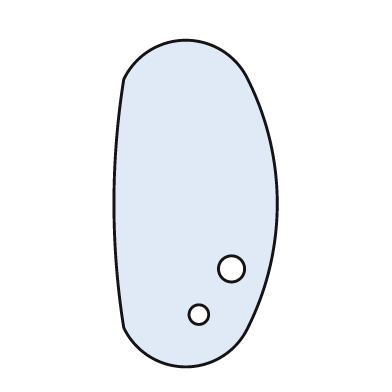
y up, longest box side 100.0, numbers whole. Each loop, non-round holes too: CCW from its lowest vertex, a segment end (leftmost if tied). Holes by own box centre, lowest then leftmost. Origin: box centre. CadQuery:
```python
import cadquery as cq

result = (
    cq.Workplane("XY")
    .moveTo(-22.0, -38.0)
    .threePointArc((-3.0, -50.0), (16.0, -38.0))
    .threePointArc((25.0, 0.0), (16.0, 38.0))
    .threePointArc((-3.0, 50.0), (-22.0, 38.0))
    .threePointArc((-25.0, 0.0), (-22.0, -38.0))
    .close()
    .moveTo(1.0, -34.0)
    .circle(3.0)
    .moveTo(11.0, -20.0)
    .circle(4.0)
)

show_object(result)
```